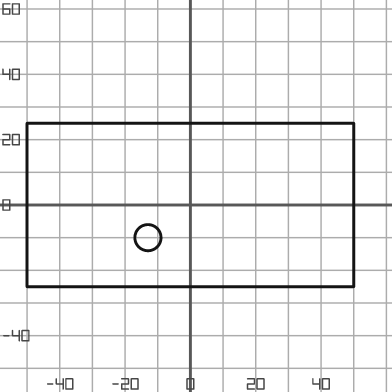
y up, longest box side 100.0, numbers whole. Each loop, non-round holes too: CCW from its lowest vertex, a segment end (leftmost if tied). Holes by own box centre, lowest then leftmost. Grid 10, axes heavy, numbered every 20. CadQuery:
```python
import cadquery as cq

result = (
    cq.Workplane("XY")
    .moveTo(-50.0, -25.0)
    .lineTo(50.0, -25.0)
    .lineTo(50.0, 25.0)
    .lineTo(-50.0, 25.0)
    .close()
    .moveTo(-13.0, -10.0)
    .circle(4.0)
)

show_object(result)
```